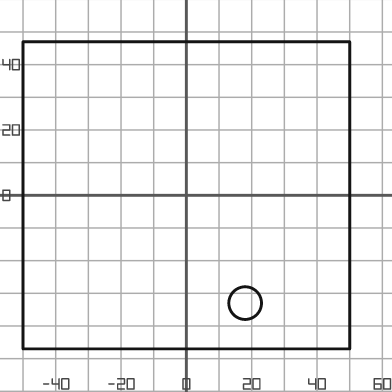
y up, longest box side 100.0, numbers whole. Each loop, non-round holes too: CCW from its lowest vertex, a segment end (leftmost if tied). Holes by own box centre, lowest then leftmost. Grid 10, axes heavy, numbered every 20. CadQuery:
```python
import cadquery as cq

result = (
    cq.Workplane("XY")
    .moveTo(-50.0, -47.0)
    .lineTo(50.0, -47.0)
    .lineTo(50.0, 47.0)
    .lineTo(-50.0, 47.0)
    .close()
    .moveTo(18.0, -33.0)
    .circle(5.0)
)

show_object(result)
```